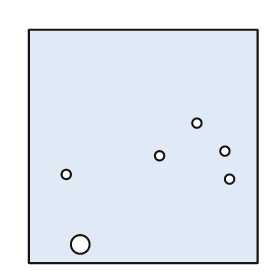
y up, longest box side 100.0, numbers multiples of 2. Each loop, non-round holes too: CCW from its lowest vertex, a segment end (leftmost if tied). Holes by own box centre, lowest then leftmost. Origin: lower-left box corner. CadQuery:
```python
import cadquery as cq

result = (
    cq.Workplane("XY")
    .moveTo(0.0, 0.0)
    .lineTo(98.0, 0.0)
    .lineTo(98.0, 100.0)
    .lineTo(0.0, 100.0)
    .close()
    .moveTo(22.0, 8.0)
    .circle(4.0)
    .moveTo(86.0, 36.0)
    .circle(2.0)
    .moveTo(16.0, 38.0)
    .circle(2.0)
    .moveTo(56.0, 46.0)
    .circle(2.0)
    .moveTo(84.0, 48.0)
    .circle(2.0)
    .moveTo(72.0, 60.0)
    .circle(2.0)
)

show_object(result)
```